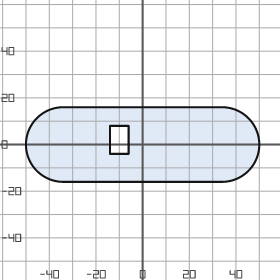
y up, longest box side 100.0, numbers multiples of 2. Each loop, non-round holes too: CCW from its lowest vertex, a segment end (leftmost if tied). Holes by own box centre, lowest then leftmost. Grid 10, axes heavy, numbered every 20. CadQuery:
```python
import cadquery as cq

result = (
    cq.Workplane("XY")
    .moveTo(-34.0, -16.0)
    .lineTo(34.0, -16.0)
    .threePointArc((50.0, 0.0), (34.0, 16.0))
    .lineTo(-34.0, 16.0)
    .threePointArc((-50.0, 0.0), (-34.0, -16.0))
    .close()
    .moveTo(-14.0, -4.0)
    .lineTo(-6.0, -4.0)
    .lineTo(-6.0, 8.0)
    .lineTo(-14.0, 8.0)
    .close()
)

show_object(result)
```